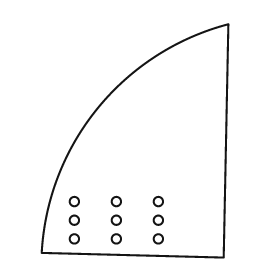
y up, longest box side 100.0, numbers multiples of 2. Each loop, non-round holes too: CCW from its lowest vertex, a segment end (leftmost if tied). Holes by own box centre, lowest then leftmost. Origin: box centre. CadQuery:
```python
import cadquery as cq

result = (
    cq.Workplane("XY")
    .moveTo(38.0, -50.0)
    .lineTo(40.0, 50.0)
    .threePointArc((-16.0, 14.0), (-40.0, -48.0))
    .close()
    .moveTo(-26.0, -42.0)
    .circle(2.0)
    .moveTo(-8.0, -42.0)
    .circle(2.0)
    .moveTo(10.0, -42.0)
    .circle(2.0)
    .moveTo(-26.0, -34.0)
    .circle(2.0)
    .moveTo(-8.0, -34.0)
    .circle(2.0)
    .moveTo(10.0, -34.0)
    .circle(2.0)
    .moveTo(-26.0, -26.0)
    .circle(2.0)
    .moveTo(-8.0, -26.0)
    .circle(2.0)
    .moveTo(10.0, -26.0)
    .circle(2.0)
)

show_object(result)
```